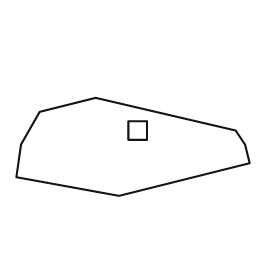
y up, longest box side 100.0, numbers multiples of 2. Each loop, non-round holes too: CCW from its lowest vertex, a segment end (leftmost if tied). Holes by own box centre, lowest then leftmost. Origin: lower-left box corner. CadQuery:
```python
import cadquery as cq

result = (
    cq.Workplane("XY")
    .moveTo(44.0, 0.0)
    .lineTo(100.0, 14.0)
    .lineTo(98.0, 22.0)
    .lineTo(94.0, 28.0)
    .lineTo(34.0, 42.0)
    .lineTo(10.0, 36.0)
    .lineTo(2.0, 22.0)
    .lineTo(0.0, 8.0)
    .close()
    .moveTo(48.0, 24.0)
    .lineTo(56.0, 24.0)
    .lineTo(56.0, 32.0)
    .lineTo(48.0, 32.0)
    .close()
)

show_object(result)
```